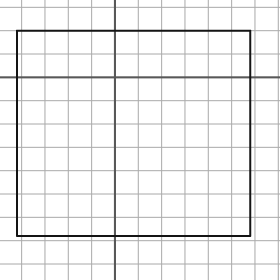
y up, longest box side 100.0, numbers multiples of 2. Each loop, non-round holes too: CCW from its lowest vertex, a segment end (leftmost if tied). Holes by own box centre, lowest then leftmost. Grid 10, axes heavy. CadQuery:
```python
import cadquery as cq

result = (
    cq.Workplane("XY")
    .moveTo(-42.0, -68.0)
    .lineTo(58.0, -68.0)
    .lineTo(58.0, 20.0)
    .lineTo(-42.0, 20.0)
    .close()
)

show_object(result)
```